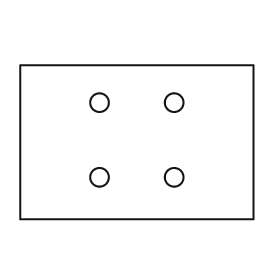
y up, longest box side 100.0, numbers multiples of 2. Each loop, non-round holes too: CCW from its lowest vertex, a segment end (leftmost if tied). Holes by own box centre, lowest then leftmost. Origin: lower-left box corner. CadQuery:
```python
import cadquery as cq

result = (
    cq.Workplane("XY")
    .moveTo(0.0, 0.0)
    .lineTo(100.0, 0.0)
    .lineTo(100.0, 66.0)
    .lineTo(0.0, 66.0)
    .close()
    .moveTo(34.0, 18.0)
    .circle(4.0)
    .moveTo(66.0, 18.0)
    .circle(4.0)
    .moveTo(34.0, 50.0)
    .circle(4.0)
    .moveTo(66.0, 50.0)
    .circle(4.0)
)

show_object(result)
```